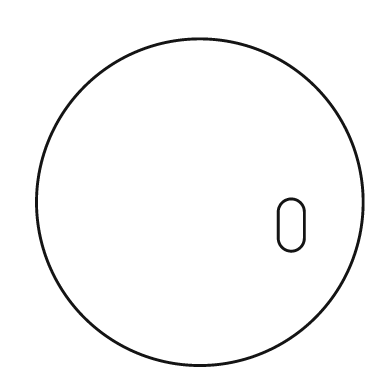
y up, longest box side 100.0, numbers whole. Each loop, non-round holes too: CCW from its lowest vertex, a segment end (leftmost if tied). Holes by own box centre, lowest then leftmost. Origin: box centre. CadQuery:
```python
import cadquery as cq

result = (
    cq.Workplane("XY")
    .moveTo(0.0, 0.0)
    .circle(50.0)
    .moveTo(24.0, -11.0)
    .threePointArc((28.0, -15.0), (32.0, -11.0))
    .lineTo(32.0, -3.0)
    .threePointArc((28.0, 1.0), (24.0, -3.0))
    .close()
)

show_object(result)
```